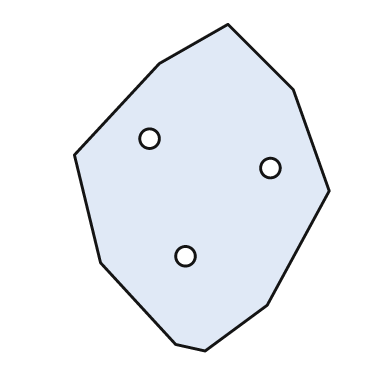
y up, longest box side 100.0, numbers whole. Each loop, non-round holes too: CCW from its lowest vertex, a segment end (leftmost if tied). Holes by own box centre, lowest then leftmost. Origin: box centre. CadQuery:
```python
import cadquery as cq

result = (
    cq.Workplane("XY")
    .moveTo(1.0, -50.0)
    .lineTo(20.0, -36.0)
    .lineTo(39.0, -1.0)
    .lineTo(28.0, 30.0)
    .lineTo(8.0, 50.0)
    .lineTo(-13.0, 38.0)
    .lineTo(-39.0, 10.0)
    .lineTo(-31.0, -23.0)
    .lineTo(-8.0, -48.0)
    .close()
    .moveTo(-5.0, -21.0)
    .circle(3.0)
    .moveTo(21.0, 6.0)
    .circle(3.0)
    .moveTo(-16.0, 15.0)
    .circle(3.0)
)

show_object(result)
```